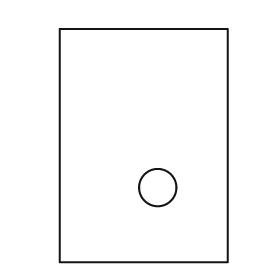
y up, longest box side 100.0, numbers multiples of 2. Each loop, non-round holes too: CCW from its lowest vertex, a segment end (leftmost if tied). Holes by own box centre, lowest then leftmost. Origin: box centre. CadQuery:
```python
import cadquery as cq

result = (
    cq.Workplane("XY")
    .moveTo(-36.0, -50.0)
    .lineTo(36.0, -50.0)
    .lineTo(36.0, 50.0)
    .lineTo(-36.0, 50.0)
    .close()
    .moveTo(6.0, -18.0)
    .circle(8.0)
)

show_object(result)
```